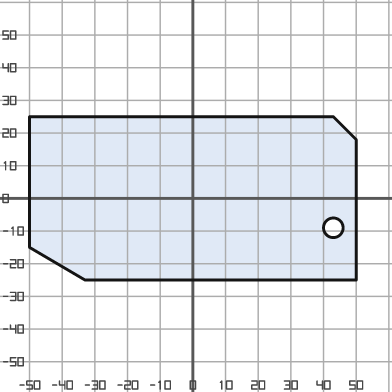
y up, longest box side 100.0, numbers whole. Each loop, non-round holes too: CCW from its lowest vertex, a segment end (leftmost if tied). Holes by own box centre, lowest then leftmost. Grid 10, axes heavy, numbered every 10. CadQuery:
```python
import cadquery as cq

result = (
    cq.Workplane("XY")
    .moveTo(-33.0, -25.0)
    .lineTo(50.0, -25.0)
    .lineTo(50.0, 18.0)
    .lineTo(43.0, 25.0)
    .lineTo(-50.0, 25.0)
    .lineTo(-50.0, -15.0)
    .close()
    .moveTo(43.0, -9.0)
    .circle(3.0)
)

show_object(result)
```